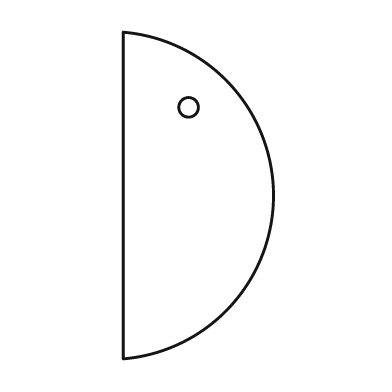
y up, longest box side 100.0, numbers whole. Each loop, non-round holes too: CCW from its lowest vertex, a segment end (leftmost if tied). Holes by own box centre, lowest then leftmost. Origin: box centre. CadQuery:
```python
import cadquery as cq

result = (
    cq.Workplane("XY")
    .moveTo(-23.0, -50.0)
    .threePointArc((23.0, 0.0), (-23.0, 50.0))
    .close()
    .moveTo(-3.0, 27.0)
    .circle(3.0)
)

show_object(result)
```